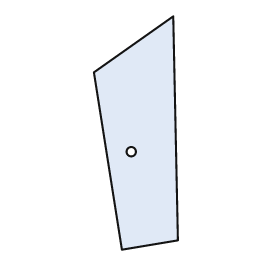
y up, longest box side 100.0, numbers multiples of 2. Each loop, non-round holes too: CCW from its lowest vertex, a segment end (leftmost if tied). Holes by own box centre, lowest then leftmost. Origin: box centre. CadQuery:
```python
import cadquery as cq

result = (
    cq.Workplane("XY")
    .moveTo(-6.0, -50.0)
    .lineTo(18.0, -46.0)
    .lineTo(16.0, 50.0)
    .lineTo(-18.0, 26.0)
    .close()
    .moveTo(-2.0, -8.0)
    .circle(2.0)
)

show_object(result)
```